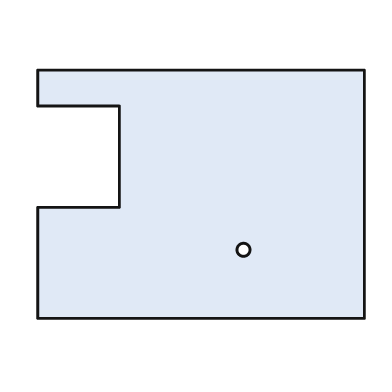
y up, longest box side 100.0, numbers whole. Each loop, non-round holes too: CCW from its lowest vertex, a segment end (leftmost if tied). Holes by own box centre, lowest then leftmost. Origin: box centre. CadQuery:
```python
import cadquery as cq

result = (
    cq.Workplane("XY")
    .moveTo(-50.0, -38.0)
    .lineTo(50.0, -38.0)
    .lineTo(50.0, 38.0)
    .lineTo(-50.0, 38.0)
    .lineTo(-50.0, 27.0)
    .lineTo(-25.0, 27.0)
    .lineTo(-25.0, -4.0)
    .lineTo(-50.0, -4.0)
    .close()
    .moveTo(13.0, -17.0)
    .circle(2.0)
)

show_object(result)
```